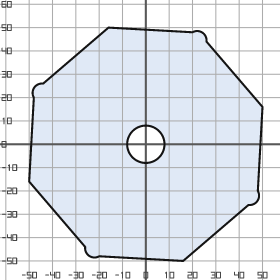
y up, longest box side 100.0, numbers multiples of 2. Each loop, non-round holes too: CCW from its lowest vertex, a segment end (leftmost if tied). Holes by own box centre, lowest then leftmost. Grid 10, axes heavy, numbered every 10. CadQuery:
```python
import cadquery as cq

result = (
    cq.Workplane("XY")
    .moveTo(16.0, -50.0)
    .lineTo(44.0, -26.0)
    .threePointArc((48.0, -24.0), (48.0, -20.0))
    .lineTo(50.0, 16.0)
    .lineTo(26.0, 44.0)
    .threePointArc((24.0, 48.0), (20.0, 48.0))
    .lineTo(-16.0, 50.0)
    .lineTo(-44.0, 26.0)
    .threePointArc((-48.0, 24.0), (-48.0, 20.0))
    .lineTo(-50.0, -16.0)
    .lineTo(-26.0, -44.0)
    .threePointArc((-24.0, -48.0), (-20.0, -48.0))
    .close()
    .moveTo(0.0, 0.0)
    .circle(8.0)
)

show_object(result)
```